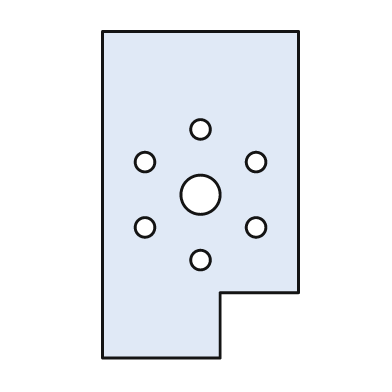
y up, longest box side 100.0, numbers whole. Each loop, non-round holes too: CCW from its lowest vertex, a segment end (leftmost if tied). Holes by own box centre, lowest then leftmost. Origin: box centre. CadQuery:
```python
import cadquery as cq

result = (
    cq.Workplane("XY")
    .moveTo(-30.0, -50.0)
    .lineTo(6.0, -50.0)
    .lineTo(6.0, -30.0)
    .lineTo(30.0, -30.0)
    .lineTo(30.0, 50.0)
    .lineTo(-30.0, 50.0)
    .close()
    .moveTo(0.0, -20.0)
    .circle(3.0)
    .moveTo(-17.0, -10.0)
    .circle(3.0)
    .moveTo(17.0, -10.0)
    .circle(3.0)
    .moveTo(0.0, 0.0)
    .circle(6.0)
    .moveTo(-17.0, 10.0)
    .circle(3.0)
    .moveTo(17.0, 10.0)
    .circle(3.0)
    .moveTo(0.0, 20.0)
    .circle(3.0)
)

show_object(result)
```